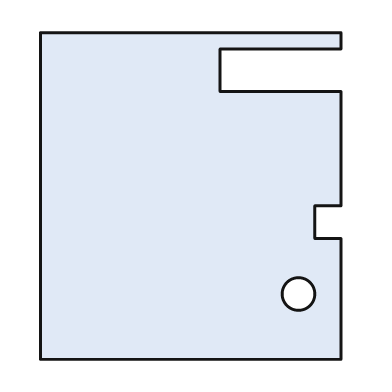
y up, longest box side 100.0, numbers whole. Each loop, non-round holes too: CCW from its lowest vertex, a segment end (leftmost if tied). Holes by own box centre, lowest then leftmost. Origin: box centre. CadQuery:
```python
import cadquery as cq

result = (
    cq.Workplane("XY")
    .moveTo(-46.0, -50.0)
    .lineTo(46.0, -50.0)
    .lineTo(46.0, -13.0)
    .lineTo(38.0, -13.0)
    .lineTo(38.0, -3.0)
    .lineTo(46.0, -3.0)
    .lineTo(46.0, 32.0)
    .lineTo(9.0, 32.0)
    .lineTo(9.0, 45.0)
    .lineTo(46.0, 45.0)
    .lineTo(46.0, 50.0)
    .lineTo(-46.0, 50.0)
    .close()
    .moveTo(33.0, -30.0)
    .circle(5.0)
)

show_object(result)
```